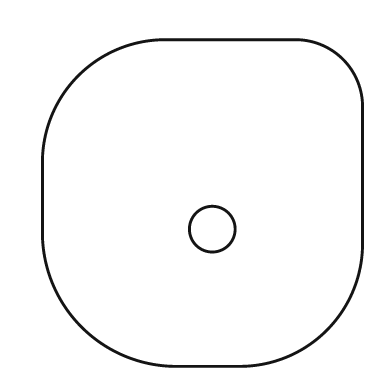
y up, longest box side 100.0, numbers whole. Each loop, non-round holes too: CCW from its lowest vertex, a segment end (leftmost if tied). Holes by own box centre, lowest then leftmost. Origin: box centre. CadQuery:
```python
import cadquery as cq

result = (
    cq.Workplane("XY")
    .moveTo(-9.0, -50.0)
    .lineTo(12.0, -50.0)
    .threePointArc((38.0, -39.0), (49.0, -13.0))
    .lineTo(49.0, 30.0)
    .threePointArc((43.0, 44.0), (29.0, 50.0))
    .lineTo(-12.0, 50.0)
    .threePointArc((-38.0, 39.0), (-49.0, 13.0))
    .lineTo(-49.0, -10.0)
    .threePointArc((-37.0, -38.0), (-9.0, -50.0))
    .close()
    .moveTo(3.0, -8.0)
    .circle(7.0)
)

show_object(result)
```